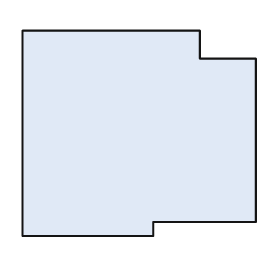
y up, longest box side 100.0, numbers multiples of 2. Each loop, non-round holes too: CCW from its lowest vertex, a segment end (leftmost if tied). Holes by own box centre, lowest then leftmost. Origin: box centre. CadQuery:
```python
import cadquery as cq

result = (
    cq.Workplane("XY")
    .moveTo(-50.0, -44.0)
    .lineTo(6.0, -44.0)
    .lineTo(6.0, -38.0)
    .lineTo(50.0, -38.0)
    .lineTo(50.0, 32.0)
    .lineTo(26.0, 32.0)
    .lineTo(26.0, 44.0)
    .lineTo(-50.0, 44.0)
    .close()
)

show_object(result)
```